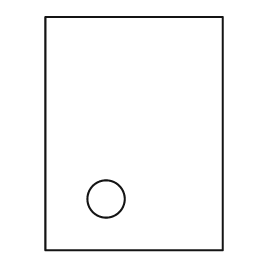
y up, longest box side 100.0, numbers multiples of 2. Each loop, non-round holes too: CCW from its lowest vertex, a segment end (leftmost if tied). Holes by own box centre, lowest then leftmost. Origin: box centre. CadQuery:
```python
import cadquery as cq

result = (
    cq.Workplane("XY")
    .moveTo(-38.0, -50.0)
    .lineTo(38.0, -50.0)
    .lineTo(38.0, 50.0)
    .lineTo(-38.0, 50.0)
    .close()
    .moveTo(-12.0, -28.0)
    .circle(8.0)
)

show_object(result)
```